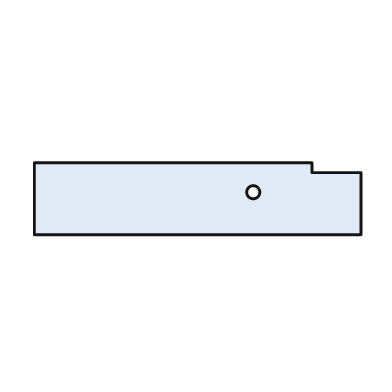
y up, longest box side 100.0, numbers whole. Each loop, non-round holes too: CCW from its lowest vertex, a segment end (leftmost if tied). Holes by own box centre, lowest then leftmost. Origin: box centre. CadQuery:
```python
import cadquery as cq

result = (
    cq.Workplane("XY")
    .moveTo(-50.0, -11.0)
    .lineTo(50.0, -11.0)
    .lineTo(50.0, 8.0)
    .lineTo(35.0, 8.0)
    .lineTo(35.0, 11.0)
    .lineTo(-50.0, 11.0)
    .close()
    .moveTo(17.0, 2.0)
    .circle(2.0)
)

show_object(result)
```